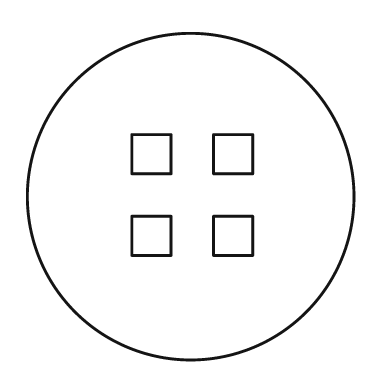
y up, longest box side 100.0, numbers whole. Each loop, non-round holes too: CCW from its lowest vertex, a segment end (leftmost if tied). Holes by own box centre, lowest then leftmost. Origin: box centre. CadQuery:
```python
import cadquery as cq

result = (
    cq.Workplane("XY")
    .moveTo(0.0, 0.0)
    .circle(50.0)
    .moveTo(-18.0, -18.0)
    .lineTo(-6.0, -18.0)
    .lineTo(-6.0, -6.0)
    .lineTo(-18.0, -6.0)
    .close()
    .moveTo(7.0, -18.0)
    .lineTo(19.0, -18.0)
    .lineTo(19.0, -6.0)
    .lineTo(7.0, -6.0)
    .close()
    .moveTo(-18.0, 7.0)
    .lineTo(-6.0, 7.0)
    .lineTo(-6.0, 19.0)
    .lineTo(-18.0, 19.0)
    .close()
    .moveTo(7.0, 7.0)
    .lineTo(19.0, 7.0)
    .lineTo(19.0, 19.0)
    .lineTo(7.0, 19.0)
    .close()
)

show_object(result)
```